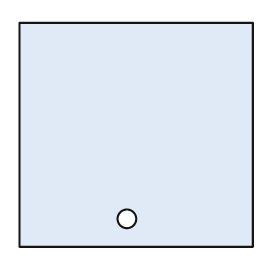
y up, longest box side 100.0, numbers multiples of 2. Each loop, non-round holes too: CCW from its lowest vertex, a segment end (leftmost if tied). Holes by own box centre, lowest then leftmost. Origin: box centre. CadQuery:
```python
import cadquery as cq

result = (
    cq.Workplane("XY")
    .moveTo(-50.0, -48.0)
    .lineTo(50.0, -48.0)
    .lineTo(50.0, 48.0)
    .lineTo(-50.0, 48.0)
    .close()
    .moveTo(-4.0, -36.0)
    .circle(4.0)
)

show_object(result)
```